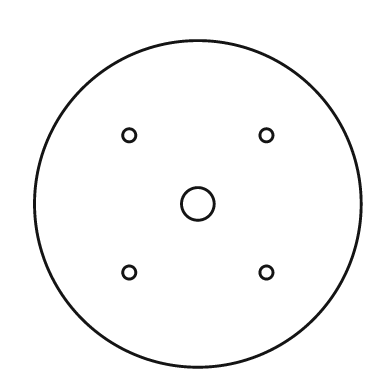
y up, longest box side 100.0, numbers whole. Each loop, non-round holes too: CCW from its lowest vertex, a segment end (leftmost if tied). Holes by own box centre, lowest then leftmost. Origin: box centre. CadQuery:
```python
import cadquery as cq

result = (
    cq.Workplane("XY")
    .moveTo(0.0, 0.0)
    .circle(50.0)
    .moveTo(-21.0, -21.0)
    .circle(2.0)
    .moveTo(21.0, -21.0)
    .circle(2.0)
    .moveTo(0.0, 0.0)
    .circle(5.0)
    .moveTo(-21.0, 21.0)
    .circle(2.0)
    .moveTo(21.0, 21.0)
    .circle(2.0)
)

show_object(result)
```